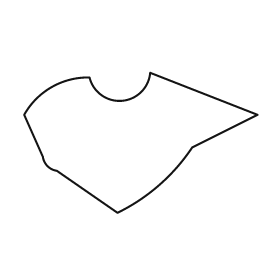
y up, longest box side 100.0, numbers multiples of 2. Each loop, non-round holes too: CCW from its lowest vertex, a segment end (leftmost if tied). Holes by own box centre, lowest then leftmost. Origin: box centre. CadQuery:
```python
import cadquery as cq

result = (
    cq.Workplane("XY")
    .moveTo(-10.0, -30.0)
    .threePointArc((8.0, -18.0), (22.0, -2.0))
    .lineTo(50.0, 12.0)
    .lineTo(4.0, 30.0)
    .threePointArc((-8.0, 18.0), (-22.0, 28.0))
    .threePointArc((-38.0, 24.0), (-50.0, 12.0))
    .lineTo(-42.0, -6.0)
    .threePointArc((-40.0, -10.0), (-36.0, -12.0))
    .close()
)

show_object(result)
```